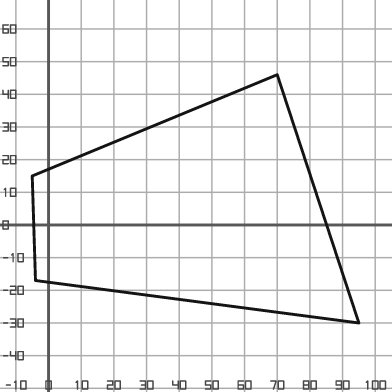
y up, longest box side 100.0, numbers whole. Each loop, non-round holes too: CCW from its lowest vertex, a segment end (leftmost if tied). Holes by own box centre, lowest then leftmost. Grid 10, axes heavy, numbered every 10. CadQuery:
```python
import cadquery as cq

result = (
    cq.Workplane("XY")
    .moveTo(95.0, -30.0)
    .lineTo(70.0, 46.0)
    .lineTo(-5.0, 15.0)
    .lineTo(-4.0, -17.0)
    .close()
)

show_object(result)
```